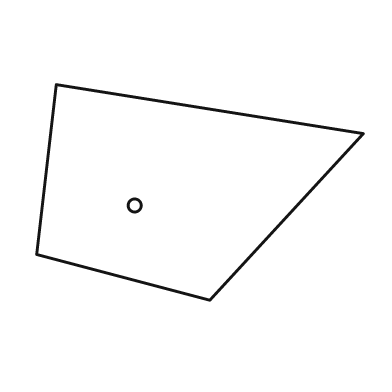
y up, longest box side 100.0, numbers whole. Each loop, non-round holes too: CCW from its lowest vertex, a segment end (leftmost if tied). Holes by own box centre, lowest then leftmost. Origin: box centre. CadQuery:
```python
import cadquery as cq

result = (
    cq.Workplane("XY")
    .moveTo(3.0, -33.0)
    .lineTo(50.0, 18.0)
    .lineTo(-44.0, 33.0)
    .lineTo(-50.0, -19.0)
    .close()
    .moveTo(-20.0, -4.0)
    .circle(2.0)
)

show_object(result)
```